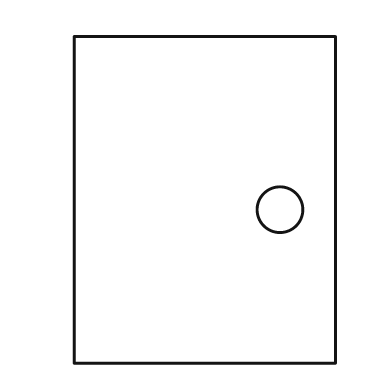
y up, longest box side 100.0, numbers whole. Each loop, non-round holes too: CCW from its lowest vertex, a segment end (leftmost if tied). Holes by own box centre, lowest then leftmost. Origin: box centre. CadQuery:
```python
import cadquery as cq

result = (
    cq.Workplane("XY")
    .moveTo(-40.0, -50.0)
    .lineTo(40.0, -50.0)
    .lineTo(40.0, 50.0)
    .lineTo(-40.0, 50.0)
    .close()
    .moveTo(23.0, -3.0)
    .circle(7.0)
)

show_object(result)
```